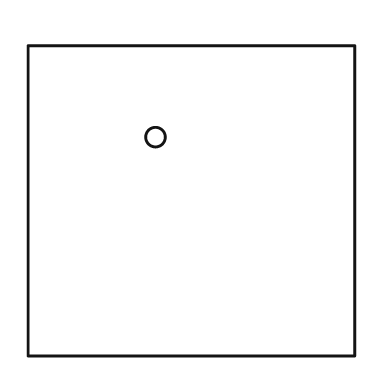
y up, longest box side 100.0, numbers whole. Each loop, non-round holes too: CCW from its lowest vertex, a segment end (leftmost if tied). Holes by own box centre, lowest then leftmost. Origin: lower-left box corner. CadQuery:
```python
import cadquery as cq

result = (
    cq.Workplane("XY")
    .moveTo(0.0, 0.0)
    .lineTo(100.0, 0.0)
    .lineTo(100.0, 95.0)
    .lineTo(0.0, 95.0)
    .close()
    .moveTo(39.0, 67.0)
    .circle(3.0)
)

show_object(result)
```